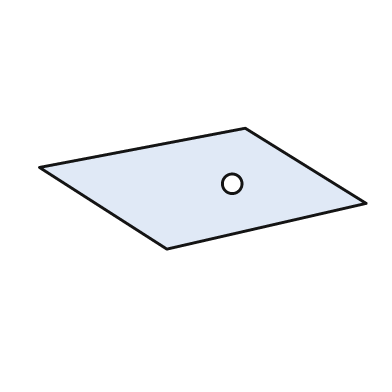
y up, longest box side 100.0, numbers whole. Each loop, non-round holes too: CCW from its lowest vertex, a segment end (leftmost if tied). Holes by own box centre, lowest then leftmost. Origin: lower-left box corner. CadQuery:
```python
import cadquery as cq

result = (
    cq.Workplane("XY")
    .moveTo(39.0, 0.0)
    .lineTo(100.0, 14.0)
    .lineTo(63.0, 37.0)
    .lineTo(0.0, 25.0)
    .close()
    .moveTo(59.0, 20.0)
    .circle(3.0)
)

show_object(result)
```